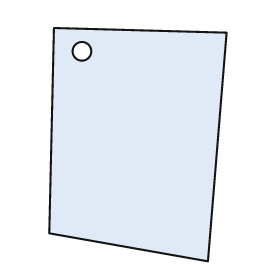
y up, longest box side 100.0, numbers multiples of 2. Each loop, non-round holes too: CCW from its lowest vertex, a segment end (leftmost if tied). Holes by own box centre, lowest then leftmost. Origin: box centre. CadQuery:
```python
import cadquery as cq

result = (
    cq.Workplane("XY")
    .moveTo(30.0, -50.0)
    .lineTo(38.0, 48.0)
    .lineTo(-36.0, 50.0)
    .lineTo(-38.0, -38.0)
    .close()
    .moveTo(-24.0, 40.0)
    .circle(4.0)
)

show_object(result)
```